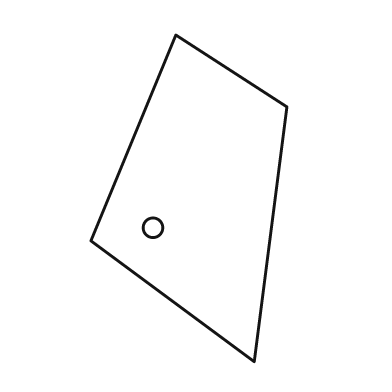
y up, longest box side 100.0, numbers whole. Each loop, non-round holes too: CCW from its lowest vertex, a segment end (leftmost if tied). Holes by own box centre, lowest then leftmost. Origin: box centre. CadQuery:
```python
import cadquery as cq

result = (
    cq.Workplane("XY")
    .moveTo(20.0, -50.0)
    .lineTo(30.0, 28.0)
    .lineTo(-4.0, 50.0)
    .lineTo(-30.0, -13.0)
    .close()
    .moveTo(-11.0, -9.0)
    .circle(3.0)
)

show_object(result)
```